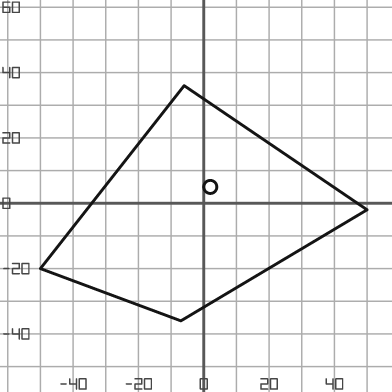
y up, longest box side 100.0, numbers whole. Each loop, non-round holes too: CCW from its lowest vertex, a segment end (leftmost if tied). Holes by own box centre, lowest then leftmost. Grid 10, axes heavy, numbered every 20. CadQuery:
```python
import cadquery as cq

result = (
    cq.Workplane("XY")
    .moveTo(-7.0, -36.0)
    .lineTo(50.0, -2.0)
    .lineTo(-6.0, 36.0)
    .lineTo(-50.0, -20.0)
    .close()
    .moveTo(2.0, 5.0)
    .circle(2.0)
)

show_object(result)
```